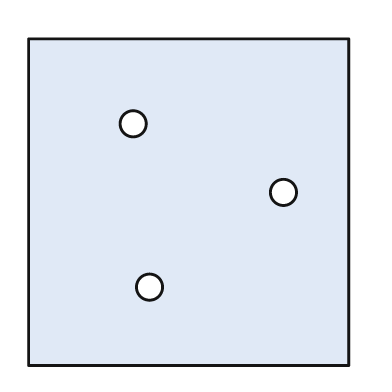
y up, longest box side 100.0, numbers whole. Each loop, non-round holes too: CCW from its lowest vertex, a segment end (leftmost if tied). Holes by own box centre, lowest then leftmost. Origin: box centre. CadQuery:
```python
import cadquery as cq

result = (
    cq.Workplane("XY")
    .moveTo(-49.0, -50.0)
    .lineTo(49.0, -50.0)
    .lineTo(49.0, 50.0)
    .lineTo(-49.0, 50.0)
    .close()
    .moveTo(-12.0, -26.0)
    .circle(4.0)
    .moveTo(29.0, 3.0)
    .circle(4.0)
    .moveTo(-17.0, 24.0)
    .circle(4.0)
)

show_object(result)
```